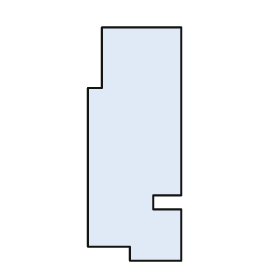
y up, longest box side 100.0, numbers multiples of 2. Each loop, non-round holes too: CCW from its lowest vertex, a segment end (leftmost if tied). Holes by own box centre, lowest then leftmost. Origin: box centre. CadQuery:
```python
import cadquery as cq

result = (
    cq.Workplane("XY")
    .moveTo(-2.0, -50.0)
    .lineTo(20.0, -50.0)
    .lineTo(20.0, -28.0)
    .lineTo(8.0, -28.0)
    .lineTo(8.0, -22.0)
    .lineTo(20.0, -22.0)
    .lineTo(20.0, 50.0)
    .lineTo(-14.0, 50.0)
    .lineTo(-14.0, 24.0)
    .lineTo(-20.0, 24.0)
    .lineTo(-20.0, -44.0)
    .lineTo(-2.0, -44.0)
    .close()
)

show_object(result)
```